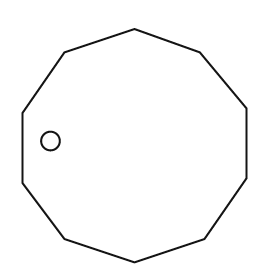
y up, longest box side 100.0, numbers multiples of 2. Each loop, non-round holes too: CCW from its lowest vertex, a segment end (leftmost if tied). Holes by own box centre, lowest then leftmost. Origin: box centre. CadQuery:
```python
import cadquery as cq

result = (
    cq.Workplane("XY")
    .moveTo(0.0, -50.0)
    .lineTo(30.0, -40.0)
    .lineTo(48.0, -14.0)
    .lineTo(48.0, 16.0)
    .lineTo(28.0, 40.0)
    .lineTo(0.0, 50.0)
    .lineTo(-30.0, 40.0)
    .lineTo(-48.0, 14.0)
    .lineTo(-48.0, -16.0)
    .lineTo(-30.0, -40.0)
    .close()
    .moveTo(-36.0, 2.0)
    .circle(4.0)
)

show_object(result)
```